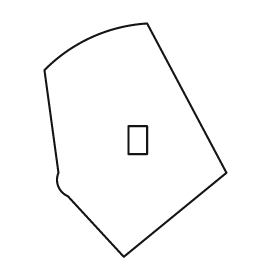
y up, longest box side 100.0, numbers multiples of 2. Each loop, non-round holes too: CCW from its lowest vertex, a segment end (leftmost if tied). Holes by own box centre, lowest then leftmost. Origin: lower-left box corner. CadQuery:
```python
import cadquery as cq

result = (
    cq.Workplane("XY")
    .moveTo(34.0, 0.0)
    .lineTo(78.0, 36.0)
    .lineTo(44.0, 100.0)
    .threePointArc((20.0, 94.0), (0.0, 80.0))
    .lineTo(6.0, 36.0)
    .threePointArc((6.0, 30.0), (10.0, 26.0))
    .close()
    .moveTo(36.0, 44.0)
    .lineTo(44.0, 44.0)
    .lineTo(44.0, 56.0)
    .lineTo(36.0, 56.0)
    .close()
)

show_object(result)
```